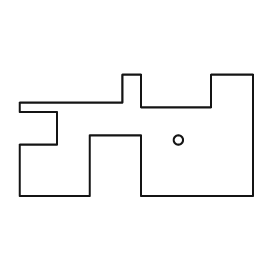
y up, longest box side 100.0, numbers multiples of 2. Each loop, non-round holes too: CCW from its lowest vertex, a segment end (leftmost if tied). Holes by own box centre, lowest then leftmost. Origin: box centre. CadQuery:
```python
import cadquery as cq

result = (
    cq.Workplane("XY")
    .moveTo(-50.0, -26.0)
    .lineTo(-20.0, -26.0)
    .lineTo(-20.0, 0.0)
    .lineTo(2.0, 0.0)
    .lineTo(2.0, -26.0)
    .lineTo(50.0, -26.0)
    .lineTo(50.0, 26.0)
    .lineTo(32.0, 26.0)
    .lineTo(32.0, 12.0)
    .lineTo(2.0, 12.0)
    .lineTo(2.0, 26.0)
    .lineTo(-6.0, 26.0)
    .lineTo(-6.0, 14.0)
    .lineTo(-50.0, 14.0)
    .lineTo(-50.0, 10.0)
    .lineTo(-34.0, 10.0)
    .lineTo(-34.0, -4.0)
    .lineTo(-50.0, -4.0)
    .close()
    .moveTo(18.0, -2.0)
    .circle(2.0)
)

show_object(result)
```